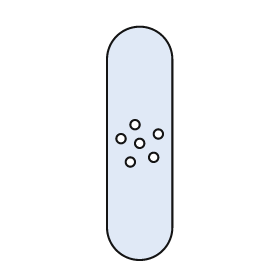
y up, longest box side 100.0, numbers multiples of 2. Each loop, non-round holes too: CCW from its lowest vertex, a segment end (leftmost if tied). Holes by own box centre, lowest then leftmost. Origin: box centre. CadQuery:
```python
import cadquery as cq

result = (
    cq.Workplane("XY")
    .moveTo(-14.0, -36.0)
    .threePointArc((0.0, -50.0), (14.0, -36.0))
    .lineTo(14.0, 36.0)
    .threePointArc((0.0, 50.0), (-14.0, 36.0))
    .close()
    .moveTo(-4.0, -8.0)
    .circle(2.0)
    .moveTo(6.0, -6.0)
    .circle(2.0)
    .moveTo(0.0, 0.0)
    .circle(2.0)
    .moveTo(-8.0, 2.0)
    .circle(2.0)
    .moveTo(8.0, 4.0)
    .circle(2.0)
    .moveTo(-2.0, 8.0)
    .circle(2.0)
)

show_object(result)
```